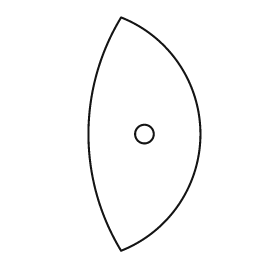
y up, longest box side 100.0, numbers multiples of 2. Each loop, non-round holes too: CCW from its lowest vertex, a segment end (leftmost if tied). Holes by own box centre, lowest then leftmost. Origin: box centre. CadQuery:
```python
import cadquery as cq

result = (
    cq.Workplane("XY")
    .moveTo(-10.0, -50.0)
    .threePointArc((24.0, 0.0), (-10.0, 50.0))
    .threePointArc((-24.0, 0.0), (-10.0, -50.0))
    .close()
    .moveTo(0.0, 0.0)
    .circle(4.0)
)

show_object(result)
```